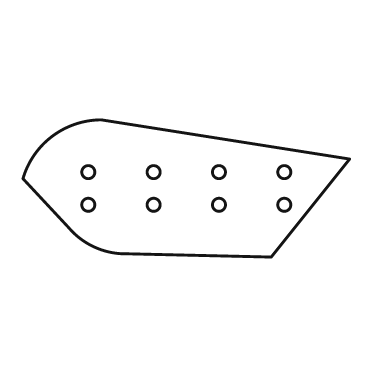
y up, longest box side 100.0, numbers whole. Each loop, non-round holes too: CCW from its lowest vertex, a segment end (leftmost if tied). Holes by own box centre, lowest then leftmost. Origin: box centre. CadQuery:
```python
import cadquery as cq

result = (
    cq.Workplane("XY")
    .moveTo(26.0, -21.0)
    .lineTo(50.0, 9.0)
    .lineTo(-26.0, 21.0)
    .threePointArc((-41.0, 16.0), (-50.0, 3.0))
    .lineTo(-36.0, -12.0)
    .threePointArc((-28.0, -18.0), (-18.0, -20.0))
    .close()
    .moveTo(-30.0, -5.0)
    .circle(2.0)
    .moveTo(-10.0, -5.0)
    .circle(2.0)
    .moveTo(10.0, -5.0)
    .circle(2.0)
    .moveTo(30.0, -5.0)
    .circle(2.0)
    .moveTo(-30.0, 5.0)
    .circle(2.0)
    .moveTo(-10.0, 5.0)
    .circle(2.0)
    .moveTo(10.0, 5.0)
    .circle(2.0)
    .moveTo(30.0, 5.0)
    .circle(2.0)
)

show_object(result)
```